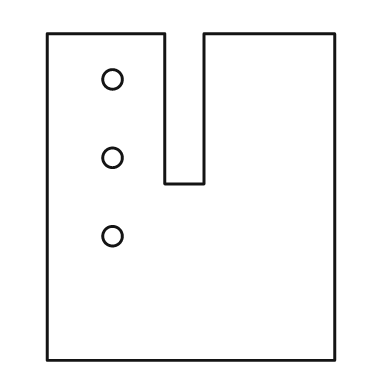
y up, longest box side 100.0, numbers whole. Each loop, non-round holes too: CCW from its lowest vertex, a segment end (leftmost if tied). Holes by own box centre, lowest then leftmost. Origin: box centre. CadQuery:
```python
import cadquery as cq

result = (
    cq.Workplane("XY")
    .moveTo(-44.0, -50.0)
    .lineTo(44.0, -50.0)
    .lineTo(44.0, 50.0)
    .lineTo(4.0, 50.0)
    .lineTo(4.0, 4.0)
    .lineTo(-8.0, 4.0)
    .lineTo(-8.0, 50.0)
    .lineTo(-44.0, 50.0)
    .close()
    .moveTo(-24.0, -12.0)
    .circle(3.0)
    .moveTo(-24.0, 12.0)
    .circle(3.0)
    .moveTo(-24.0, 36.0)
    .circle(3.0)
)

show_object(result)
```